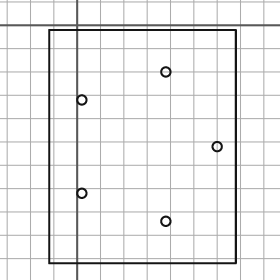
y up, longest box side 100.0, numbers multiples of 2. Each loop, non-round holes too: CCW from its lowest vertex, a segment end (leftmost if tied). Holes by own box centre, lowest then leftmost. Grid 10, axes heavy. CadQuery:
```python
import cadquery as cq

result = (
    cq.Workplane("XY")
    .moveTo(-12.0, -102.0)
    .lineTo(68.0, -102.0)
    .lineTo(68.0, -2.0)
    .lineTo(-12.0, -2.0)
    .close()
    .moveTo(38.0, -84.0)
    .circle(2.0)
    .moveTo(2.0, -72.0)
    .circle(2.0)
    .moveTo(60.0, -52.0)
    .circle(2.0)
    .moveTo(2.0, -32.0)
    .circle(2.0)
    .moveTo(38.0, -20.0)
    .circle(2.0)
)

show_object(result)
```